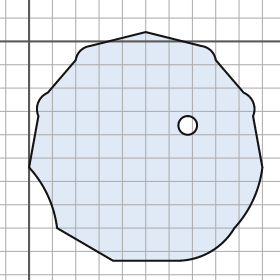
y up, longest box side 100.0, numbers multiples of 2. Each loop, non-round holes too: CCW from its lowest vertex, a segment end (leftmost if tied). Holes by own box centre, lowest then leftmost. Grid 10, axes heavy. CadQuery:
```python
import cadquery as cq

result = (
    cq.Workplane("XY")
    .moveTo(36.0, -94.0)
    .lineTo(64.0, -94.0)
    .threePointArc((78.0, -90.0), (88.0, -80.0))
    .threePointArc((96.0, -68.0), (100.0, -54.0))
    .lineTo(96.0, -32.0)
    .threePointArc((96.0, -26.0), (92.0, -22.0))
    .lineTo(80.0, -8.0)
    .threePointArc((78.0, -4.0), (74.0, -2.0))
    .lineTo(50.0, 4.0)
    .lineTo(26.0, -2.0)
    .threePointArc((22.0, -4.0), (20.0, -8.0))
    .lineTo(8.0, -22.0)
    .threePointArc((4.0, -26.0), (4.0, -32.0))
    .lineTo(0.0, -54.0)
    .threePointArc((8.0, -66.0), (12.0, -80.0))
    .close()
    .moveTo(68.0, -36.0)
    .circle(4.0)
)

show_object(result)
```